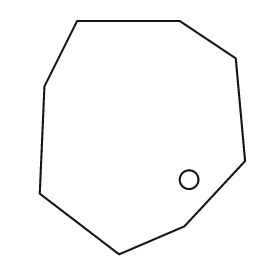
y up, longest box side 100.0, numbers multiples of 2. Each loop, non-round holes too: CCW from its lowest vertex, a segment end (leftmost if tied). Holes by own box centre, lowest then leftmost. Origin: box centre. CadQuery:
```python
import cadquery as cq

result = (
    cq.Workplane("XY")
    .moveTo(-10.0, -50.0)
    .lineTo(18.0, -38.0)
    .lineTo(44.0, -10.0)
    .lineTo(40.0, 34.0)
    .lineTo(16.0, 50.0)
    .lineTo(-28.0, 50.0)
    .lineTo(-42.0, 22.0)
    .lineTo(-44.0, -24.0)
    .close()
    .moveTo(20.0, -18.0)
    .circle(4.0)
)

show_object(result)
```